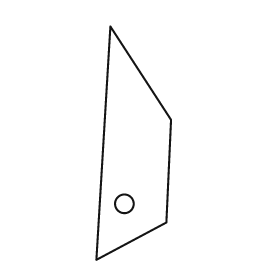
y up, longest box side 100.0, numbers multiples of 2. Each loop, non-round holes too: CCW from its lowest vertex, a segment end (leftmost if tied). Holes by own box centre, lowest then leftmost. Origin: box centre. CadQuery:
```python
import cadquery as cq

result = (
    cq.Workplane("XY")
    .moveTo(-16.0, -50.0)
    .lineTo(14.0, -34.0)
    .lineTo(16.0, 10.0)
    .lineTo(-10.0, 50.0)
    .close()
    .moveTo(-4.0, -26.0)
    .circle(4.0)
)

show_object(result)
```